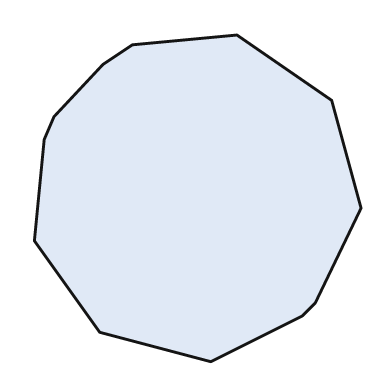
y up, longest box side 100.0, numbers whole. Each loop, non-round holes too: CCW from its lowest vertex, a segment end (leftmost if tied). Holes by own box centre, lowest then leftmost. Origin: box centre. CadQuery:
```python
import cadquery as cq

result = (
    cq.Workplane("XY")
    .moveTo(4.0, -50.0)
    .lineTo(32.0, -36.0)
    .lineTo(36.0, -32.0)
    .lineTo(50.0, -3.0)
    .lineTo(41.0, 30.0)
    .lineTo(12.0, 50.0)
    .lineTo(-20.0, 47.0)
    .lineTo(-29.0, 41.0)
    .lineTo(-44.0, 25.0)
    .lineTo(-47.0, 18.0)
    .lineTo(-50.0, -13.0)
    .lineTo(-30.0, -41.0)
    .close()
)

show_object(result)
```